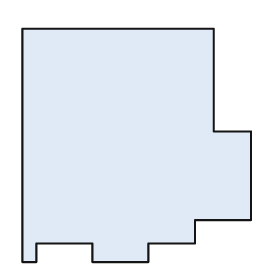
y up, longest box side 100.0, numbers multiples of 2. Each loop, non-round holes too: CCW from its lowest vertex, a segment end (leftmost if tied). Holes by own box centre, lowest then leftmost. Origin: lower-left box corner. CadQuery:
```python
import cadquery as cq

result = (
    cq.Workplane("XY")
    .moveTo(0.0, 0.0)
    .lineTo(6.0, 0.0)
    .lineTo(6.0, 8.0)
    .lineTo(30.0, 8.0)
    .lineTo(30.0, 0.0)
    .lineTo(54.0, 0.0)
    .lineTo(54.0, 8.0)
    .lineTo(74.0, 8.0)
    .lineTo(74.0, 18.0)
    .lineTo(98.0, 18.0)
    .lineTo(98.0, 56.0)
    .lineTo(82.0, 56.0)
    .lineTo(82.0, 100.0)
    .lineTo(0.0, 100.0)
    .close()
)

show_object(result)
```